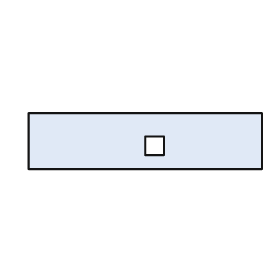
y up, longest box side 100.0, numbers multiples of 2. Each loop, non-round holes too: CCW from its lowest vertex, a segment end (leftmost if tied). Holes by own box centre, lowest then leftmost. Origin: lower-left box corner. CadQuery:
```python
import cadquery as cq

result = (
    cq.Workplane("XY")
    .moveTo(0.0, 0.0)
    .lineTo(100.0, 0.0)
    .lineTo(100.0, 24.0)
    .lineTo(0.0, 24.0)
    .close()
    .moveTo(50.0, 6.0)
    .lineTo(58.0, 6.0)
    .lineTo(58.0, 14.0)
    .lineTo(50.0, 14.0)
    .close()
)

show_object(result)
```